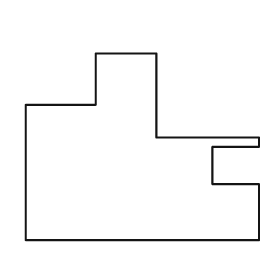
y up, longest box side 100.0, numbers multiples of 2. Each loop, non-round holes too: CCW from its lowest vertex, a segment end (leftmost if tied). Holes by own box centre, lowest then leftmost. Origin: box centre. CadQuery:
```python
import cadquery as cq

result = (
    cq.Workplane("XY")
    .moveTo(-50.0, -40.0)
    .lineTo(50.0, -40.0)
    .lineTo(50.0, -16.0)
    .lineTo(30.0, -16.0)
    .lineTo(30.0, 0.0)
    .lineTo(50.0, 0.0)
    .lineTo(50.0, 4.0)
    .lineTo(6.0, 4.0)
    .lineTo(6.0, 40.0)
    .lineTo(-20.0, 40.0)
    .lineTo(-20.0, 18.0)
    .lineTo(-50.0, 18.0)
    .close()
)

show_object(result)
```